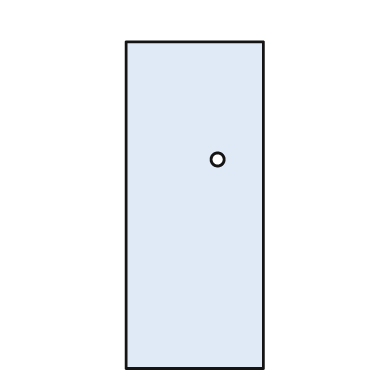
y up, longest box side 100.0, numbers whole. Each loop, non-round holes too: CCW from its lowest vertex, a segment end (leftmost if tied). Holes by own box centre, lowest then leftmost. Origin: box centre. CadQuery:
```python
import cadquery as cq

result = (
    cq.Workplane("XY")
    .moveTo(-21.0, -50.0)
    .lineTo(21.0, -50.0)
    .lineTo(21.0, 50.0)
    .lineTo(-21.0, 50.0)
    .close()
    .moveTo(7.0, 14.0)
    .circle(2.0)
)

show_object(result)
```